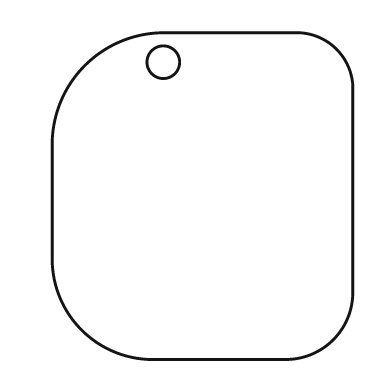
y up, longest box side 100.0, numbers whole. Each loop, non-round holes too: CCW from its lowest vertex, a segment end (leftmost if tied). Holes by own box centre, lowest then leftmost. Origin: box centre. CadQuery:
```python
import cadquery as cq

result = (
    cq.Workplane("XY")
    .moveTo(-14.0, -50.0)
    .lineTo(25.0, -50.0)
    .threePointArc((40.0, -44.0), (46.0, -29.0))
    .lineTo(46.0, 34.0)
    .threePointArc((41.0, 45.0), (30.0, 50.0))
    .lineTo(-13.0, 50.0)
    .threePointArc((-36.0, 40.0), (-46.0, 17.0))
    .lineTo(-46.0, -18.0)
    .threePointArc((-37.0, -41.0), (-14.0, -50.0))
    .close()
    .moveTo(-12.0, 41.0)
    .circle(5.0)
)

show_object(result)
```